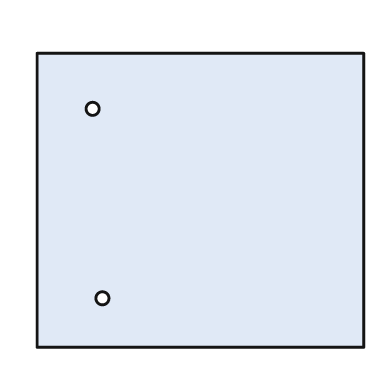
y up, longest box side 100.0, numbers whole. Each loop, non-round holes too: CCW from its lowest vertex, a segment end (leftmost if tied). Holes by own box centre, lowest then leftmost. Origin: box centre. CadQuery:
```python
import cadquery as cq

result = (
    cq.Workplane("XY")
    .moveTo(-50.0, -45.0)
    .lineTo(50.0, -45.0)
    .lineTo(50.0, 45.0)
    .lineTo(-50.0, 45.0)
    .close()
    .moveTo(-30.0, -30.0)
    .circle(2.0)
    .moveTo(-33.0, 28.0)
    .circle(2.0)
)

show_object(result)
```